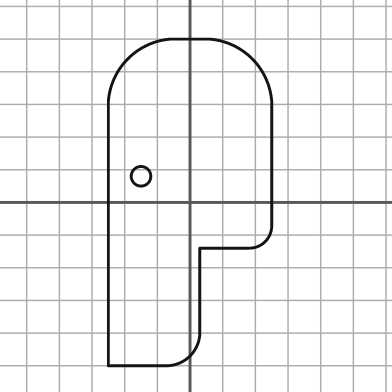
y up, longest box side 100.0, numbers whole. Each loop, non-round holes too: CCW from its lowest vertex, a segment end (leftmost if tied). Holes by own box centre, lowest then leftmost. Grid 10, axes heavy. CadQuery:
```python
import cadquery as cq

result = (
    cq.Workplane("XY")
    .moveTo(-25.0, -50.0)
    .lineTo(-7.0, -50.0)
    .threePointArc((0.0, -47.0), (3.0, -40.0))
    .lineTo(3.0, -14.0)
    .lineTo(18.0, -14.0)
    .threePointArc((23.0, -12.0), (25.0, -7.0))
    .lineTo(25.0, 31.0)
    .threePointArc((19.0, 44.0), (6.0, 50.0))
    .lineTo(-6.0, 50.0)
    .threePointArc((-19.0, 44.0), (-25.0, 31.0))
    .close()
    .moveTo(-15.0, 8.0)
    .circle(3.0)
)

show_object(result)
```